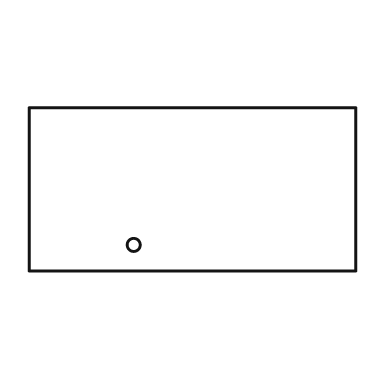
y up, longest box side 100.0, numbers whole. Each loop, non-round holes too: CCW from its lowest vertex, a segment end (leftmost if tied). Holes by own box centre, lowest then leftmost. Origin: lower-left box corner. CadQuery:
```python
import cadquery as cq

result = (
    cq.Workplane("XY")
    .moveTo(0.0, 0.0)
    .lineTo(100.0, 0.0)
    .lineTo(100.0, 50.0)
    .lineTo(0.0, 50.0)
    .close()
    .moveTo(32.0, 8.0)
    .circle(2.0)
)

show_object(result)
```